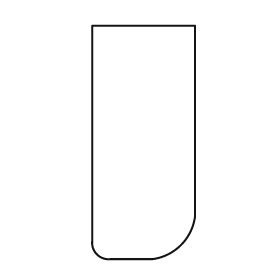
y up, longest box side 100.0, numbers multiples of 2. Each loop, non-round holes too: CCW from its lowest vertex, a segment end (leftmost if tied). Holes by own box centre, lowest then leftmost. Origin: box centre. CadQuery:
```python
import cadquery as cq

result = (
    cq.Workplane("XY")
    .moveTo(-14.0, -50.0)
    .lineTo(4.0, -50.0)
    .threePointArc((16.0, -44.0), (22.0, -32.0))
    .lineTo(22.0, 50.0)
    .lineTo(-22.0, 50.0)
    .lineTo(-22.0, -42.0)
    .threePointArc((-20.0, -48.0), (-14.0, -50.0))
    .close()
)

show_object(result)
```